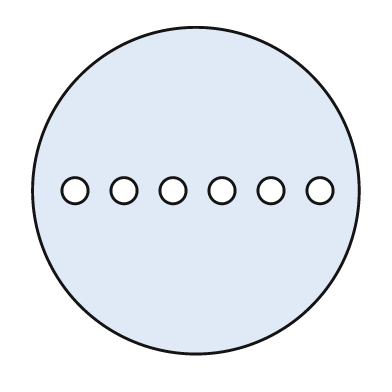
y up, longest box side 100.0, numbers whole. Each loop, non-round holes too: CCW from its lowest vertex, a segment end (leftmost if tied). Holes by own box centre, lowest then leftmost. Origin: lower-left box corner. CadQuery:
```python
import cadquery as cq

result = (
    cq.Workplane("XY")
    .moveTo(50.0, 50.0)
    .circle(50.0)
    .moveTo(13.0, 50.0)
    .circle(4.0)
    .moveTo(28.0, 50.0)
    .circle(4.0)
    .moveTo(43.0, 50.0)
    .circle(4.0)
    .moveTo(58.0, 50.0)
    .circle(4.0)
    .moveTo(73.0, 50.0)
    .circle(4.0)
    .moveTo(88.0, 50.0)
    .circle(4.0)
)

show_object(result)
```